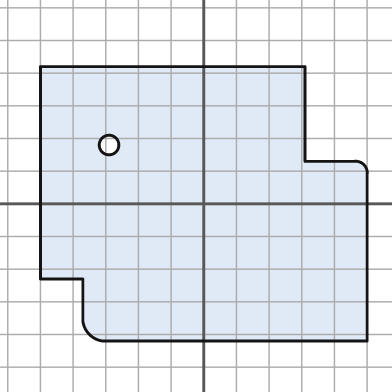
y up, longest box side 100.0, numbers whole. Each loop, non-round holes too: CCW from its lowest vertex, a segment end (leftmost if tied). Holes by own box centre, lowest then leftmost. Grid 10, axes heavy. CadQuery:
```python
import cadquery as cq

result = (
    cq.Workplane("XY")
    .moveTo(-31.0, -42.0)
    .lineTo(50.0, -42.0)
    .lineTo(50.0, 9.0)
    .threePointArc((49.0, 12.0), (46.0, 13.0))
    .lineTo(31.0, 13.0)
    .lineTo(31.0, 42.0)
    .lineTo(-50.0, 42.0)
    .lineTo(-50.0, -23.0)
    .lineTo(-37.0, -23.0)
    .lineTo(-37.0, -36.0)
    .threePointArc((-35.0, -40.0), (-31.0, -42.0))
    .close()
    .moveTo(-29.0, 18.0)
    .circle(3.0)
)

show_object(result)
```